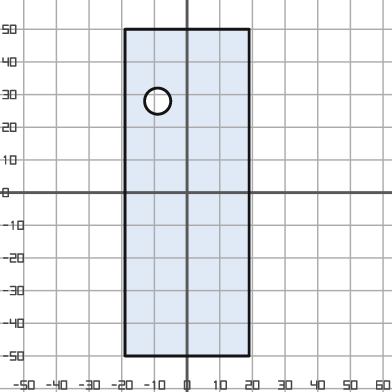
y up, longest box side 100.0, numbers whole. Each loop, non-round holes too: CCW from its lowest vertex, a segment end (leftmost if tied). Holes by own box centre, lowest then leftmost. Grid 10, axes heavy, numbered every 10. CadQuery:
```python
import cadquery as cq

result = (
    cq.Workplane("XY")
    .moveTo(-19.0, -50.0)
    .lineTo(19.0, -50.0)
    .lineTo(19.0, 50.0)
    .lineTo(-19.0, 50.0)
    .close()
    .moveTo(-9.0, 28.0)
    .circle(4.0)
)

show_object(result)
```